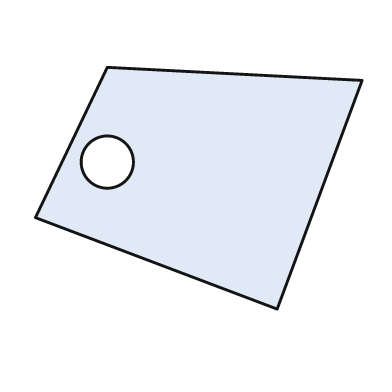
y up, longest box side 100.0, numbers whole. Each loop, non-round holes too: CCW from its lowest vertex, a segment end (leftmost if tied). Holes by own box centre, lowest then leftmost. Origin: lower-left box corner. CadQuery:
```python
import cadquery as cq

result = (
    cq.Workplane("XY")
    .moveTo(74.0, 0.0)
    .lineTo(100.0, 70.0)
    .lineTo(22.0, 74.0)
    .lineTo(0.0, 28.0)
    .close()
    .moveTo(22.0, 45.0)
    .circle(8.0)
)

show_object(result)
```